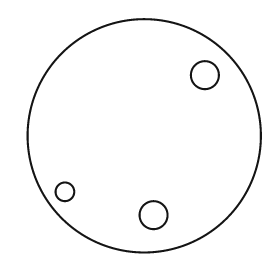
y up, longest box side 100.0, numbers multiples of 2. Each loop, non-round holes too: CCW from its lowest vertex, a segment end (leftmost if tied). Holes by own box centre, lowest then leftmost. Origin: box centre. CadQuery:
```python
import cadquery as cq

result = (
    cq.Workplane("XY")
    .moveTo(0.0, 0.0)
    .circle(50.0)
    .moveTo(4.0, -34.0)
    .circle(6.0)
    .moveTo(-34.0, -24.0)
    .circle(4.0)
    .moveTo(26.0, 26.0)
    .circle(6.0)
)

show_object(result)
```